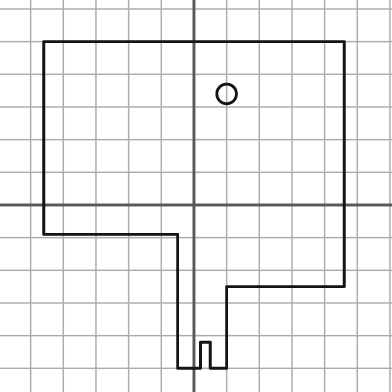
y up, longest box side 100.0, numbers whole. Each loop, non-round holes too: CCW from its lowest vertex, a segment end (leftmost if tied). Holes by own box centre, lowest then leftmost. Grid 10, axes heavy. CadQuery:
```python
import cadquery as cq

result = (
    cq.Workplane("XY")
    .moveTo(-5.0, -50.0)
    .lineTo(2.0, -50.0)
    .lineTo(2.0, -42.0)
    .lineTo(5.0, -42.0)
    .lineTo(5.0, -50.0)
    .lineTo(10.0, -50.0)
    .lineTo(10.0, -25.0)
    .lineTo(46.0, -25.0)
    .lineTo(46.0, 50.0)
    .lineTo(-46.0, 50.0)
    .lineTo(-46.0, -9.0)
    .lineTo(-5.0, -9.0)
    .close()
    .moveTo(10.0, 34.0)
    .circle(3.0)
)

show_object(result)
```